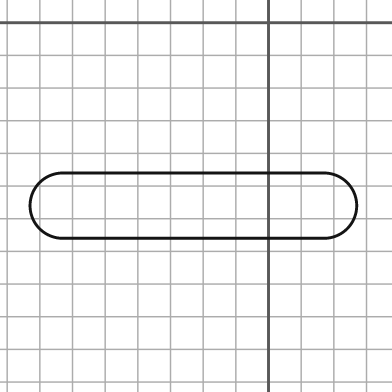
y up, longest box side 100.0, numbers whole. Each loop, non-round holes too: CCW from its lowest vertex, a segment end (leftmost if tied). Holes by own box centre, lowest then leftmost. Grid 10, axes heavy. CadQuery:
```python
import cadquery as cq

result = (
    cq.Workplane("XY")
    .moveTo(-63.0, -66.0)
    .lineTo(17.0, -66.0)
    .threePointArc((27.0, -56.0), (17.0, -46.0))
    .lineTo(-63.0, -46.0)
    .threePointArc((-73.0, -56.0), (-63.0, -66.0))
    .close()
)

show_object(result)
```